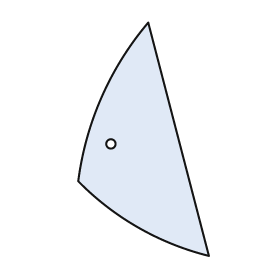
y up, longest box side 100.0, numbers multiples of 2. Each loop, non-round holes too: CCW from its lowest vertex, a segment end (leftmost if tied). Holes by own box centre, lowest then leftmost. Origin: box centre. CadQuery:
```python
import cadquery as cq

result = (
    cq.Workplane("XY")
    .moveTo(28.0, -50.0)
    .lineTo(2.0, 50.0)
    .threePointArc((-18.0, 18.0), (-28.0, -18.0))
    .threePointArc((-2.0, -38.0), (28.0, -50.0))
    .close()
    .moveTo(-14.0, -2.0)
    .circle(2.0)
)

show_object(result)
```